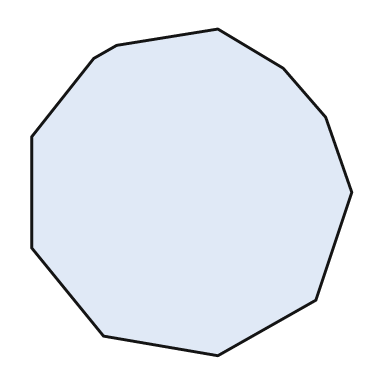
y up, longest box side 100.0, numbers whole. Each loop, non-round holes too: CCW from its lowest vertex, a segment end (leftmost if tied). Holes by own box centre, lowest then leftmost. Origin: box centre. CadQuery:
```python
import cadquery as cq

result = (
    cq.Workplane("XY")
    .moveTo(8.0, -50.0)
    .lineTo(38.0, -33.0)
    .lineTo(49.0, 0.0)
    .lineTo(41.0, 23.0)
    .lineTo(28.0, 38.0)
    .lineTo(8.0, 50.0)
    .lineTo(-23.0, 45.0)
    .lineTo(-30.0, 41.0)
    .lineTo(-49.0, 17.0)
    .lineTo(-49.0, -17.0)
    .lineTo(-27.0, -44.0)
    .close()
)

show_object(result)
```